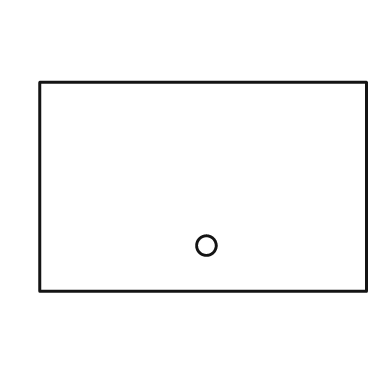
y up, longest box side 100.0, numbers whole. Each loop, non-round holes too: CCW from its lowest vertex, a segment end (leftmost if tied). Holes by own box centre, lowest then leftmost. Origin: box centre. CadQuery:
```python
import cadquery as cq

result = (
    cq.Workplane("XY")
    .moveTo(-50.0, -32.0)
    .lineTo(50.0, -32.0)
    .lineTo(50.0, 32.0)
    .lineTo(-50.0, 32.0)
    .close()
    .moveTo(1.0, -18.0)
    .circle(3.0)
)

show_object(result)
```